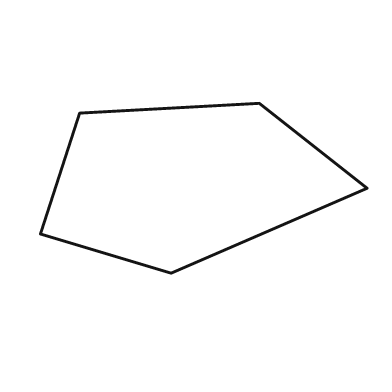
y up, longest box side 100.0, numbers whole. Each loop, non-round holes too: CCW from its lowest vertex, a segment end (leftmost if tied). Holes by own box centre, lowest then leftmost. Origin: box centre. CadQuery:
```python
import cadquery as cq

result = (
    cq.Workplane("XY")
    .moveTo(-10.0, -26.0)
    .lineTo(50.0, 0.0)
    .lineTo(17.0, 26.0)
    .lineTo(-38.0, 23.0)
    .lineTo(-50.0, -14.0)
    .close()
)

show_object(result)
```